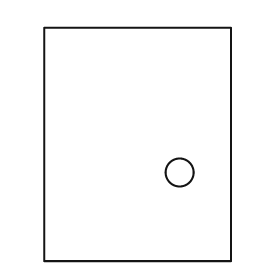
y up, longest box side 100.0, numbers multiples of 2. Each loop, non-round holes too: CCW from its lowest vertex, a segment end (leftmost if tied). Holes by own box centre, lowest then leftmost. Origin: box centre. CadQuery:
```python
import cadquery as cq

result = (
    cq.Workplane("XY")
    .moveTo(-40.0, -50.0)
    .lineTo(40.0, -50.0)
    .lineTo(40.0, 50.0)
    .lineTo(-40.0, 50.0)
    .close()
    .moveTo(18.0, -12.0)
    .circle(6.0)
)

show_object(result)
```